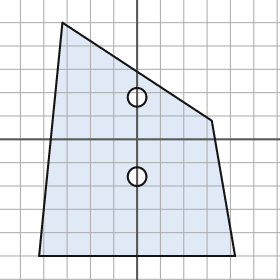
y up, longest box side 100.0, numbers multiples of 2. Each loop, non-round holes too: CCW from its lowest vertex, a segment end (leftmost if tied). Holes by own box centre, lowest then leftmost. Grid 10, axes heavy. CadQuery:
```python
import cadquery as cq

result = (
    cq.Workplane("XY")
    .moveTo(-42.0, -50.0)
    .lineTo(42.0, -50.0)
    .lineTo(32.0, 8.0)
    .lineTo(-32.0, 50.0)
    .close()
    .moveTo(0.0, -16.0)
    .circle(4.0)
    .moveTo(0.0, 18.0)
    .circle(4.0)
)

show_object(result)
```